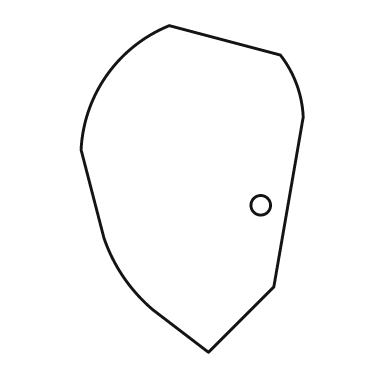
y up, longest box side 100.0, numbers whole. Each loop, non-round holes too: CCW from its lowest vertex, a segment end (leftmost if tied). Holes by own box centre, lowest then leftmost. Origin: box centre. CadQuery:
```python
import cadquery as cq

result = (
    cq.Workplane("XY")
    .moveTo(5.0, -50.0)
    .lineTo(25.0, -30.0)
    .lineTo(34.0, 22.0)
    .threePointArc((32.0, 32.0), (27.0, 41.0))
    .lineTo(-7.0, 50.0)
    .threePointArc((-26.0, 35.0), (-34.0, 12.0))
    .lineTo(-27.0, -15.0)
    .threePointArc((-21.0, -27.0), (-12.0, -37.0))
    .close()
    .moveTo(21.0, -5.0)
    .circle(3.0)
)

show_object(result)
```